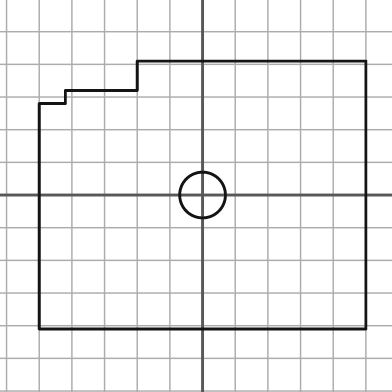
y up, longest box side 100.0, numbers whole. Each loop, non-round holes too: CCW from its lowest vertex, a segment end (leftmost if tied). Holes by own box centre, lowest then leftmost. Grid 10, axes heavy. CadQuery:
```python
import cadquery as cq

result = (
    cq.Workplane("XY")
    .moveTo(-50.0, -41.0)
    .lineTo(50.0, -41.0)
    .lineTo(50.0, 41.0)
    .lineTo(-20.0, 41.0)
    .lineTo(-20.0, 32.0)
    .lineTo(-42.0, 32.0)
    .lineTo(-42.0, 28.0)
    .lineTo(-50.0, 28.0)
    .close()
    .moveTo(0.0, 0.0)
    .circle(7.0)
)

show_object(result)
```